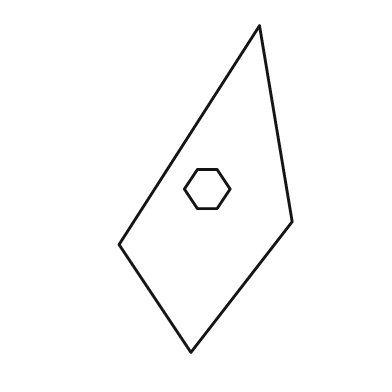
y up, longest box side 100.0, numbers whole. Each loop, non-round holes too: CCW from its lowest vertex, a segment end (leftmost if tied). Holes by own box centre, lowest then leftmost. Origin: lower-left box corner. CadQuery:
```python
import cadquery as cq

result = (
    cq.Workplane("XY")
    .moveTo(22.0, 0.0)
    .lineTo(53.0, 40.0)
    .lineTo(43.0, 100.0)
    .lineTo(0.0, 33.0)
    .close()
    .moveTo(24.0, 44.0)
    .lineTo(30.0, 44.0)
    .lineTo(34.0, 50.0)
    .lineTo(30.0, 56.0)
    .lineTo(24.0, 56.0)
    .lineTo(20.0, 50.0)
    .close()
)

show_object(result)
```